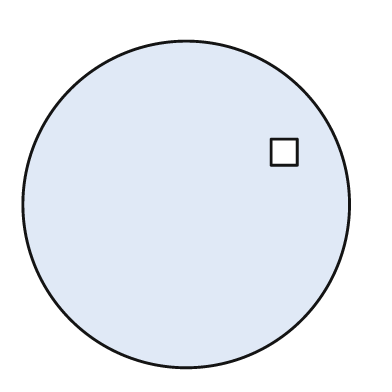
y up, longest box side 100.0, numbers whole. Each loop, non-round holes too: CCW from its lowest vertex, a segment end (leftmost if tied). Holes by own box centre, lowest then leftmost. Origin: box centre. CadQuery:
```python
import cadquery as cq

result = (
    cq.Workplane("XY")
    .moveTo(0.0, 0.0)
    .circle(50.0)
    .moveTo(26.0, 12.0)
    .lineTo(34.0, 12.0)
    .lineTo(34.0, 20.0)
    .lineTo(26.0, 20.0)
    .close()
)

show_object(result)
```